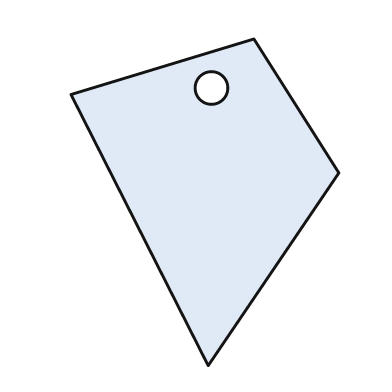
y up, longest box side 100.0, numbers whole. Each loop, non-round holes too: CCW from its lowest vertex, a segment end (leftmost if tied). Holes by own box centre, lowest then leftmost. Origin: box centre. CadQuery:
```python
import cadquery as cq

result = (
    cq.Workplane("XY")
    .moveTo(1.0, -50.0)
    .lineTo(41.0, 9.0)
    .lineTo(15.0, 50.0)
    .lineTo(-41.0, 33.0)
    .close()
    .moveTo(2.0, 35.0)
    .circle(5.0)
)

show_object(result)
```